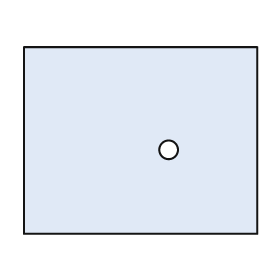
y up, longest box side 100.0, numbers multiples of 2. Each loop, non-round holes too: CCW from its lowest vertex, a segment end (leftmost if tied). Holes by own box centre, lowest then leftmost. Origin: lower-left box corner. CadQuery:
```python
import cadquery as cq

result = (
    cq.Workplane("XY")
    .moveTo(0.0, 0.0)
    .lineTo(100.0, 0.0)
    .lineTo(100.0, 80.0)
    .lineTo(0.0, 80.0)
    .close()
    .moveTo(62.0, 36.0)
    .circle(4.0)
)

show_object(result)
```